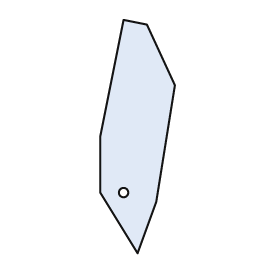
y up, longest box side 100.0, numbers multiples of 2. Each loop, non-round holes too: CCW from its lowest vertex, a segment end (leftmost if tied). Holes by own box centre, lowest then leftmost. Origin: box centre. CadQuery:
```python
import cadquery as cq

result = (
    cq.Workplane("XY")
    .moveTo(0.0, -50.0)
    .lineTo(8.0, -28.0)
    .lineTo(16.0, 22.0)
    .lineTo(4.0, 48.0)
    .lineTo(-6.0, 50.0)
    .lineTo(-16.0, 0.0)
    .lineTo(-16.0, -24.0)
    .close()
    .moveTo(-6.0, -24.0)
    .circle(2.0)
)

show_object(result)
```